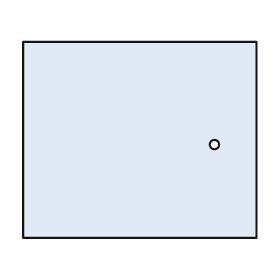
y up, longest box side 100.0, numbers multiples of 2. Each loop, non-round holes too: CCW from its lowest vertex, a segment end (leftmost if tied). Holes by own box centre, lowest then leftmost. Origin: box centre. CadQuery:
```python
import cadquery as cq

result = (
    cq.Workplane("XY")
    .moveTo(-50.0, -42.0)
    .lineTo(50.0, -42.0)
    .lineTo(50.0, 42.0)
    .lineTo(-50.0, 42.0)
    .close()
    .moveTo(32.0, -2.0)
    .circle(2.0)
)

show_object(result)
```